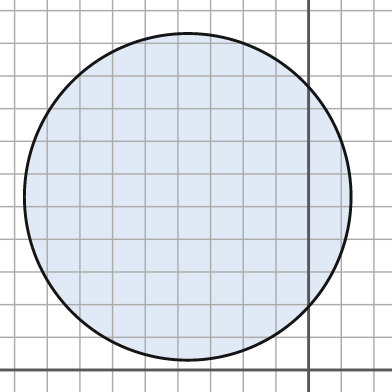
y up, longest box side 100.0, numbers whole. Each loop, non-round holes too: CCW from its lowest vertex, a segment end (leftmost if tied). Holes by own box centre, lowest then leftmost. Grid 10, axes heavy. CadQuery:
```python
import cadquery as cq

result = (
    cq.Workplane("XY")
    .moveTo(-37.0, 53.0)
    .circle(50.0)
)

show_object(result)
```